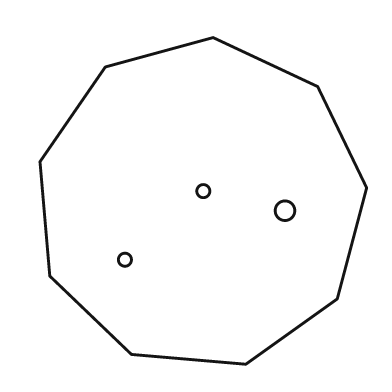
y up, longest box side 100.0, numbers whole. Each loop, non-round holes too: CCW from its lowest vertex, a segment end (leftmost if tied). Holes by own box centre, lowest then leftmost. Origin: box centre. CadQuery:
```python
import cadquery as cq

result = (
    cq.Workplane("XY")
    .moveTo(13.0, -50.0)
    .lineTo(41.0, -30.0)
    .lineTo(50.0, 4.0)
    .lineTo(35.0, 35.0)
    .lineTo(3.0, 50.0)
    .lineTo(-30.0, 41.0)
    .lineTo(-50.0, 12.0)
    .lineTo(-47.0, -23.0)
    .lineTo(-22.0, -47.0)
    .close()
    .moveTo(-24.0, -18.0)
    .circle(2.0)
    .moveTo(25.0, -3.0)
    .circle(3.0)
    .moveTo(0.0, 3.0)
    .circle(2.0)
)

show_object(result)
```